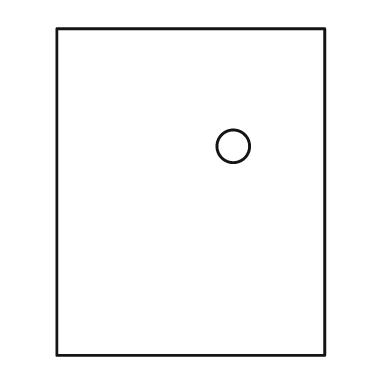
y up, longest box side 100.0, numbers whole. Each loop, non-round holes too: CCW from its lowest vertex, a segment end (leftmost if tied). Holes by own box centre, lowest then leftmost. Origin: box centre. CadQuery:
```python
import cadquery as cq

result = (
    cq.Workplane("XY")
    .moveTo(-41.0, -50.0)
    .lineTo(41.0, -50.0)
    .lineTo(41.0, 50.0)
    .lineTo(-41.0, 50.0)
    .close()
    .moveTo(13.0, 14.0)
    .circle(5.0)
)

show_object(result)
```